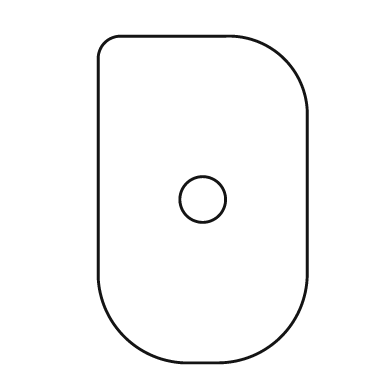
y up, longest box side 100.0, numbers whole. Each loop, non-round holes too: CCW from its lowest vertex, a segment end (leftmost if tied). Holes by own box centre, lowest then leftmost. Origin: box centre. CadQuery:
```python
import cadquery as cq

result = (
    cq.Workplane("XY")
    .moveTo(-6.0, -50.0)
    .lineTo(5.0, -50.0)
    .threePointArc((24.0, -42.0), (32.0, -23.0))
    .lineTo(32.0, 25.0)
    .threePointArc((25.0, 43.0), (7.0, 50.0))
    .lineTo(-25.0, 50.0)
    .threePointArc((-30.0, 48.0), (-32.0, 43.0))
    .lineTo(-32.0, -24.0)
    .threePointArc((-24.0, -42.0), (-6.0, -50.0))
    .close()
    .moveTo(0.0, 0.0)
    .circle(7.0)
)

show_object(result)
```